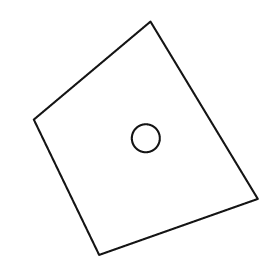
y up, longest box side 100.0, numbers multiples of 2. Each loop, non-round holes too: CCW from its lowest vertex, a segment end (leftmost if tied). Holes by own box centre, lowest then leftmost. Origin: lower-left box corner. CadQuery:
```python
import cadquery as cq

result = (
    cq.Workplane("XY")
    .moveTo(28.0, 0.0)
    .lineTo(96.0, 24.0)
    .lineTo(50.0, 100.0)
    .lineTo(0.0, 58.0)
    .close()
    .moveTo(48.0, 50.0)
    .circle(6.0)
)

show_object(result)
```